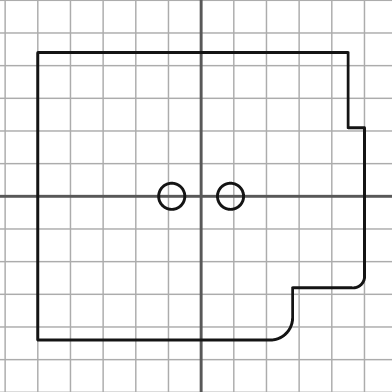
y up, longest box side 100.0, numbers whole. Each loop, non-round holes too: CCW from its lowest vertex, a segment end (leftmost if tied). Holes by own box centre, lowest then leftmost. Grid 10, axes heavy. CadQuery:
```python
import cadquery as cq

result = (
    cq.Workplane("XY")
    .moveTo(-50.0, -44.0)
    .lineTo(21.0, -44.0)
    .threePointArc((26.0, -42.0), (28.0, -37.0))
    .lineTo(28.0, -28.0)
    .lineTo(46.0, -28.0)
    .threePointArc((49.0, -27.0), (50.0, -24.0))
    .lineTo(50.0, 21.0)
    .lineTo(45.0, 21.0)
    .lineTo(45.0, 44.0)
    .lineTo(-50.0, 44.0)
    .close()
    .moveTo(-9.0, 0.0)
    .circle(4.0)
    .moveTo(9.0, 0.0)
    .circle(4.0)
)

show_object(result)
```